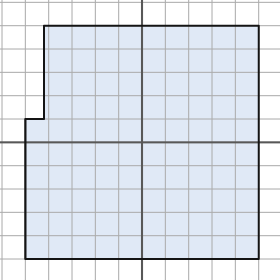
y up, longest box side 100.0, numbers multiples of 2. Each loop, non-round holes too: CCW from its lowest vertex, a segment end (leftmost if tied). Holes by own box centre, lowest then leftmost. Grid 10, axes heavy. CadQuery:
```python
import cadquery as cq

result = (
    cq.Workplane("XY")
    .moveTo(-50.0, -50.0)
    .lineTo(50.0, -50.0)
    .lineTo(50.0, 50.0)
    .lineTo(-42.0, 50.0)
    .lineTo(-42.0, 10.0)
    .lineTo(-50.0, 10.0)
    .close()
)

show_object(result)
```